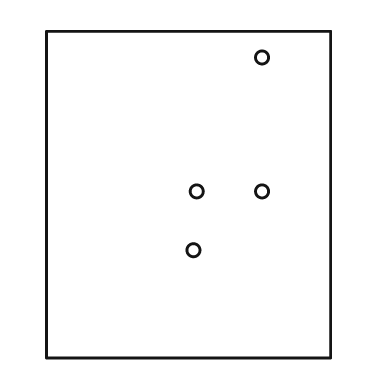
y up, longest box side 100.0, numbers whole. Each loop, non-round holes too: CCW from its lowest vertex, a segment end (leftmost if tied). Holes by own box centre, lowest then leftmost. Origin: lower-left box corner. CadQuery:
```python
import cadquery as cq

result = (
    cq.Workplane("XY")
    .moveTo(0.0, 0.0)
    .lineTo(87.0, 0.0)
    .lineTo(87.0, 100.0)
    .lineTo(0.0, 100.0)
    .close()
    .moveTo(45.0, 33.0)
    .circle(2.0)
    .moveTo(46.0, 51.0)
    .circle(2.0)
    .moveTo(66.0, 51.0)
    .circle(2.0)
    .moveTo(66.0, 92.0)
    .circle(2.0)
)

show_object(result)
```